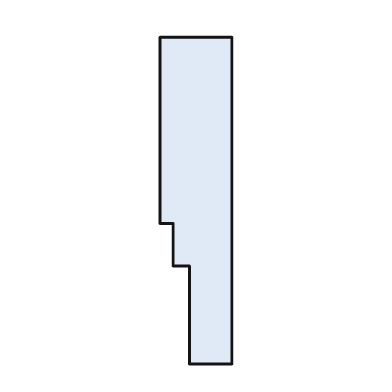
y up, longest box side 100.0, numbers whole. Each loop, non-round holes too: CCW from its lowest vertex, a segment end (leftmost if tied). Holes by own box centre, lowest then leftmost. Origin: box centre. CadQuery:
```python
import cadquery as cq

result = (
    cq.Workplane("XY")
    .moveTo(-2.0, -50.0)
    .lineTo(11.0, -50.0)
    .lineTo(11.0, 50.0)
    .lineTo(-11.0, 50.0)
    .lineTo(-11.0, -7.0)
    .lineTo(-7.0, -7.0)
    .lineTo(-7.0, -20.0)
    .lineTo(-2.0, -20.0)
    .close()
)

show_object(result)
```